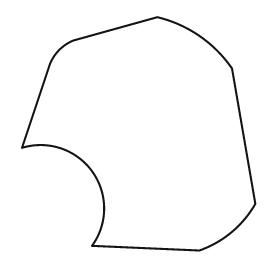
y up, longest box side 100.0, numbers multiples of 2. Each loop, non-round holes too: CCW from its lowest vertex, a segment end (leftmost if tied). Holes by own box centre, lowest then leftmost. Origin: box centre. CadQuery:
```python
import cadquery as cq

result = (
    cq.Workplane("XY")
    .moveTo(26.0, -50.0)
    .threePointArc((40.0, -42.0), (50.0, -30.0))
    .lineTo(40.0, 28.0)
    .threePointArc((26.0, 42.0), (8.0, 50.0))
    .lineTo(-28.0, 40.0)
    .threePointArc((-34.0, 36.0), (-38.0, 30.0))
    .lineTo(-50.0, -6.0)
    .threePointArc((-20.0, -16.0), (-20.0, -48.0))
    .close()
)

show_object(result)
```